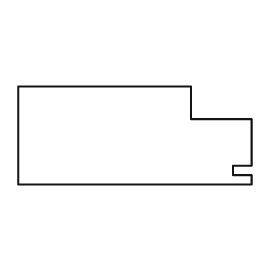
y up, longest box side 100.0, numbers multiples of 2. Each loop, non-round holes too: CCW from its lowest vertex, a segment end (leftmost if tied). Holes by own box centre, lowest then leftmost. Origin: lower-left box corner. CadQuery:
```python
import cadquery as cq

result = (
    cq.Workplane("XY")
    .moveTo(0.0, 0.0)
    .lineTo(100.0, 0.0)
    .lineTo(100.0, 4.0)
    .lineTo(92.0, 4.0)
    .lineTo(92.0, 8.0)
    .lineTo(100.0, 8.0)
    .lineTo(100.0, 28.0)
    .lineTo(74.0, 28.0)
    .lineTo(74.0, 42.0)
    .lineTo(0.0, 42.0)
    .close()
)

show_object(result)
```